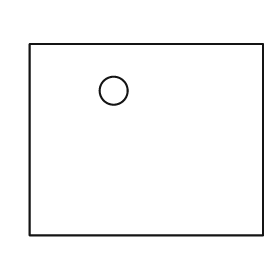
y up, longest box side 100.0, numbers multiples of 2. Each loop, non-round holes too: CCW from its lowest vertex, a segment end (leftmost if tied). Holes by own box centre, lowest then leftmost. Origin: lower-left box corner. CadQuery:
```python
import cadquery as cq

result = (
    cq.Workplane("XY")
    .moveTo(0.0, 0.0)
    .lineTo(100.0, 0.0)
    .lineTo(100.0, 82.0)
    .lineTo(0.0, 82.0)
    .close()
    .moveTo(36.0, 62.0)
    .circle(6.0)
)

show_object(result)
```